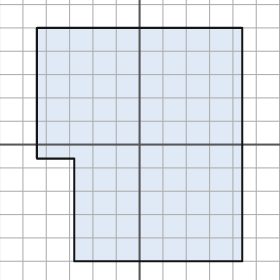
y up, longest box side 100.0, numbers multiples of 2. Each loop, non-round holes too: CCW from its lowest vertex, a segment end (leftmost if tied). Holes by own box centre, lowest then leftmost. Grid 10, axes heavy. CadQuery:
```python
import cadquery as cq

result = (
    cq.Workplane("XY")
    .moveTo(-28.0, -50.0)
    .lineTo(44.0, -50.0)
    .lineTo(44.0, 50.0)
    .lineTo(-44.0, 50.0)
    .lineTo(-44.0, -6.0)
    .lineTo(-28.0, -6.0)
    .close()
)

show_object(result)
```